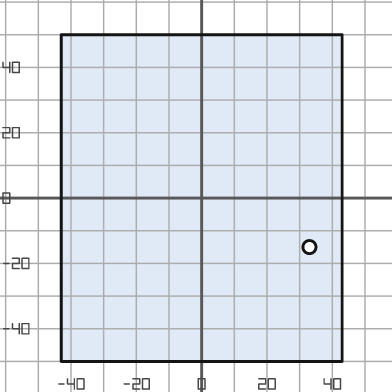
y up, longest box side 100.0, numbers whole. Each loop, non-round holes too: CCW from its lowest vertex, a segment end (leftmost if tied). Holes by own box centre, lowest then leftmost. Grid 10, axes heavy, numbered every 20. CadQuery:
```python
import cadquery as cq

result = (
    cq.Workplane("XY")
    .moveTo(-43.0, -50.0)
    .lineTo(43.0, -50.0)
    .lineTo(43.0, 50.0)
    .lineTo(-43.0, 50.0)
    .close()
    .moveTo(33.0, -15.0)
    .circle(2.0)
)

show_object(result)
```